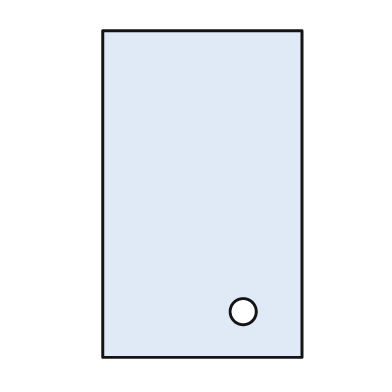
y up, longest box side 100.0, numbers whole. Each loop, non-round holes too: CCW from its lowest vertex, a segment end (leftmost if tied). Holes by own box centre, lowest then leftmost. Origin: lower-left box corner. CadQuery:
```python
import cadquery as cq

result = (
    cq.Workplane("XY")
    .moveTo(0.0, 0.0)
    .lineTo(61.0, 0.0)
    .lineTo(61.0, 100.0)
    .lineTo(0.0, 100.0)
    .close()
    .moveTo(43.0, 14.0)
    .circle(4.0)
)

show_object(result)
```